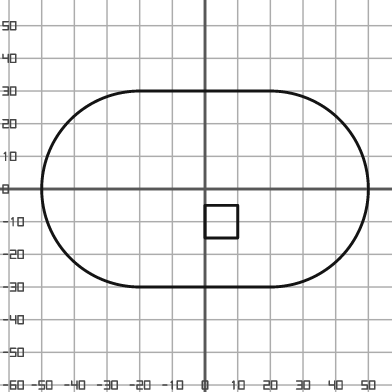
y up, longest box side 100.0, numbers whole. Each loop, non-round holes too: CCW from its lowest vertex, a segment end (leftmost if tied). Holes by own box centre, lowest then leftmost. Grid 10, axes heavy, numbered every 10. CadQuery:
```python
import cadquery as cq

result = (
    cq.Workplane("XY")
    .moveTo(-20.0, -30.0)
    .lineTo(20.0, -30.0)
    .threePointArc((50.0, 0.0), (20.0, 30.0))
    .lineTo(-20.0, 30.0)
    .threePointArc((-50.0, 0.0), (-20.0, -30.0))
    .close()
    .moveTo(0.0, -15.0)
    .lineTo(10.0, -15.0)
    .lineTo(10.0, -5.0)
    .lineTo(0.0, -5.0)
    .close()
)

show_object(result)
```